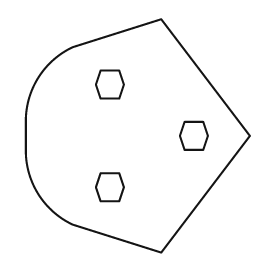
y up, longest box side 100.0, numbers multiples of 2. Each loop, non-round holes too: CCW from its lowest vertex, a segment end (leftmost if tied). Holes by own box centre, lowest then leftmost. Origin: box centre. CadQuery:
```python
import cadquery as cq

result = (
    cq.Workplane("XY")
    .moveTo(10.0, -50.0)
    .lineTo(48.0, 0.0)
    .lineTo(10.0, 50.0)
    .lineTo(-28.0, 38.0)
    .threePointArc((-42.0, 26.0), (-48.0, 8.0))
    .lineTo(-48.0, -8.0)
    .threePointArc((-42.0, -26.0), (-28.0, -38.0))
    .close()
    .moveTo(-16.0, -28.0)
    .lineTo(-8.0, -28.0)
    .lineTo(-6.0, -22.0)
    .lineTo(-8.0, -16.0)
    .lineTo(-16.0, -16.0)
    .lineTo(-18.0, -22.0)
    .close()
    .moveTo(20.0, -6.0)
    .lineTo(28.0, -6.0)
    .lineTo(30.0, 0.0)
    .lineTo(28.0, 6.0)
    .lineTo(20.0, 6.0)
    .lineTo(18.0, 0.0)
    .close()
    .moveTo(-16.0, 16.0)
    .lineTo(-8.0, 16.0)
    .lineTo(-6.0, 22.0)
    .lineTo(-8.0, 28.0)
    .lineTo(-16.0, 28.0)
    .lineTo(-18.0, 22.0)
    .close()
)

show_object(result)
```